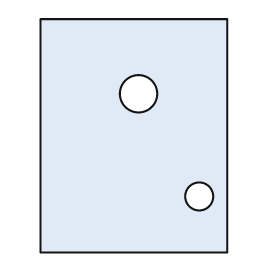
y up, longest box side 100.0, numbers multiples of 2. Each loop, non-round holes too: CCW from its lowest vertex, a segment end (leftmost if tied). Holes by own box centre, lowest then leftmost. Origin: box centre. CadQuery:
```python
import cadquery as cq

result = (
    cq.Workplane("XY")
    .moveTo(-40.0, -50.0)
    .lineTo(40.0, -50.0)
    .lineTo(40.0, 50.0)
    .lineTo(-40.0, 50.0)
    .close()
    .moveTo(28.0, -26.0)
    .circle(6.0)
    .moveTo(2.0, 18.0)
    .circle(8.0)
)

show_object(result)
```